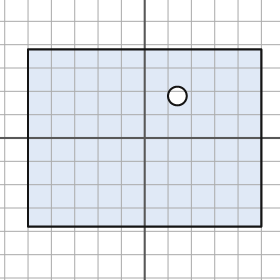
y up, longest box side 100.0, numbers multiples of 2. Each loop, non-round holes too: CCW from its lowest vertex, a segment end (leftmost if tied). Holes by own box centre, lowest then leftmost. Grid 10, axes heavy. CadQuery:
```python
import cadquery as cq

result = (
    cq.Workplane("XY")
    .moveTo(-50.0, -38.0)
    .lineTo(50.0, -38.0)
    .lineTo(50.0, 38.0)
    .lineTo(-50.0, 38.0)
    .close()
    .moveTo(14.0, 18.0)
    .circle(4.0)
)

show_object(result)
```